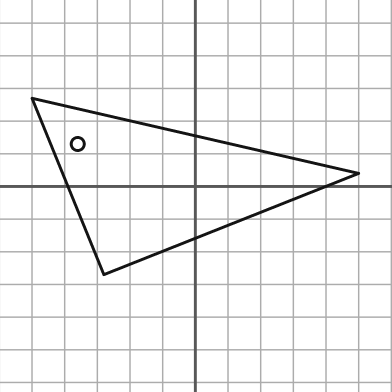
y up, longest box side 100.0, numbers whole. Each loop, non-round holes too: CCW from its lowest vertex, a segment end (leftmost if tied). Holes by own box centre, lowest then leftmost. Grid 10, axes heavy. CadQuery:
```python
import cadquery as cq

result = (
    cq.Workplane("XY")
    .moveTo(-28.0, -27.0)
    .lineTo(50.0, 4.0)
    .lineTo(-50.0, 27.0)
    .close()
    .moveTo(-36.0, 13.0)
    .circle(2.0)
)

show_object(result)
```